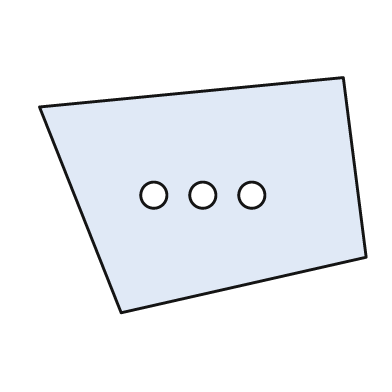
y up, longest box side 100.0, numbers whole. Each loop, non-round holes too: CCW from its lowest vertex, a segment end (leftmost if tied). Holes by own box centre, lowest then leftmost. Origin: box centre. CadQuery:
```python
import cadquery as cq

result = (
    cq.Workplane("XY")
    .moveTo(-25.0, -36.0)
    .lineTo(50.0, -19.0)
    .lineTo(43.0, 36.0)
    .lineTo(-50.0, 27.0)
    .close()
    .moveTo(-15.0, 0.0)
    .circle(4.0)
    .moveTo(0.0, 0.0)
    .circle(4.0)
    .moveTo(15.0, 0.0)
    .circle(4.0)
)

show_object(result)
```